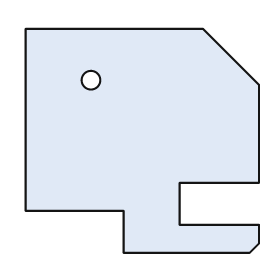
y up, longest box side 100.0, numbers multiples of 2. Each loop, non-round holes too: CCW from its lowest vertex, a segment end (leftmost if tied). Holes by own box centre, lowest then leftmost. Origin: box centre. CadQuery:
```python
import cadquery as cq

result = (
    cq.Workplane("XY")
    .moveTo(-8.0, -48.0)
    .lineTo(46.0, -48.0)
    .lineTo(50.0, -44.0)
    .lineTo(50.0, -36.0)
    .lineTo(16.0, -36.0)
    .lineTo(16.0, -18.0)
    .lineTo(50.0, -18.0)
    .lineTo(50.0, 24.0)
    .lineTo(26.0, 48.0)
    .lineTo(-50.0, 48.0)
    .lineTo(-50.0, -30.0)
    .lineTo(-8.0, -30.0)
    .close()
    .moveTo(-22.0, 26.0)
    .circle(4.0)
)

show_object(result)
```